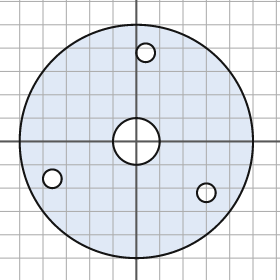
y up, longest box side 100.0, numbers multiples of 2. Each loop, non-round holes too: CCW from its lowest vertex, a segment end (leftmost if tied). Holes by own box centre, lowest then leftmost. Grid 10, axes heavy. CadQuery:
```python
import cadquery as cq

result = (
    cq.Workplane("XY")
    .moveTo(0.0, 0.0)
    .circle(50.0)
    .moveTo(30.0, -22.0)
    .circle(4.0)
    .moveTo(-36.0, -16.0)
    .circle(4.0)
    .moveTo(0.0, 0.0)
    .circle(10.0)
    .moveTo(4.0, 38.0)
    .circle(4.0)
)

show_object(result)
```